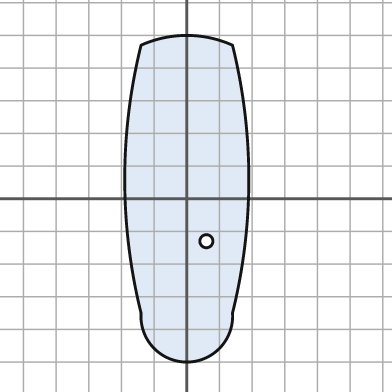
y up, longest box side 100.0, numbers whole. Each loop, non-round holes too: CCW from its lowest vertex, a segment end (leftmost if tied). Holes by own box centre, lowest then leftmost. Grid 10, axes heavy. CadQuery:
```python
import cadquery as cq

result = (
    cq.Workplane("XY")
    .moveTo(-14.0, -35.0)
    .threePointArc((0.0, -50.0), (14.0, -35.0))
    .threePointArc((19.0, 6.0), (14.0, 47.0))
    .threePointArc((0.0, 50.0), (-14.0, 47.0))
    .threePointArc((-19.0, 6.0), (-14.0, -35.0))
    .close()
    .moveTo(6.0, -13.0)
    .circle(2.0)
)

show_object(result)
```